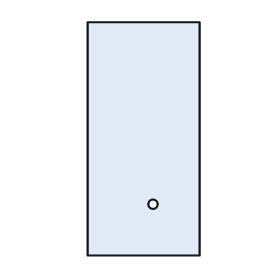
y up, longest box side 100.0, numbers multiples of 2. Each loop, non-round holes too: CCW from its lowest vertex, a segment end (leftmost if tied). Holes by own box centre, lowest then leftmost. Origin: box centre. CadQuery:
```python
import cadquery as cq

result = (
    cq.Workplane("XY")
    .moveTo(-24.0, -50.0)
    .lineTo(24.0, -50.0)
    .lineTo(24.0, 50.0)
    .lineTo(-24.0, 50.0)
    .close()
    .moveTo(4.0, -28.0)
    .circle(2.0)
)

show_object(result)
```